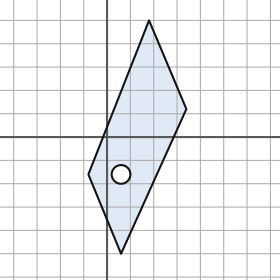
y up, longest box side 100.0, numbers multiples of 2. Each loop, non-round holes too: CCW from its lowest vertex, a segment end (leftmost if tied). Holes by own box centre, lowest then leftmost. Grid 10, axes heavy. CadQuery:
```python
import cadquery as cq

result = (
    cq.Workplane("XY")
    .moveTo(6.0, -50.0)
    .lineTo(34.0, 12.0)
    .lineTo(18.0, 50.0)
    .lineTo(-8.0, -16.0)
    .close()
    .moveTo(6.0, -16.0)
    .circle(4.0)
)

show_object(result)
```